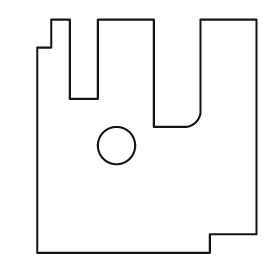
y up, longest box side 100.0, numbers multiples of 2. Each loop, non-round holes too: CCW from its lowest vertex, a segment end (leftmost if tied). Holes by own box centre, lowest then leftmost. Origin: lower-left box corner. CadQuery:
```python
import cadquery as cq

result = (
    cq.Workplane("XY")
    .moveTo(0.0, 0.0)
    .lineTo(74.0, 0.0)
    .lineTo(74.0, 8.0)
    .lineTo(94.0, 8.0)
    .lineTo(94.0, 100.0)
    .lineTo(70.0, 100.0)
    .lineTo(70.0, 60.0)
    .threePointArc((68.0, 56.0), (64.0, 54.0))
    .lineTo(50.0, 54.0)
    .lineTo(50.0, 100.0)
    .lineTo(26.0, 100.0)
    .lineTo(26.0, 66.0)
    .lineTo(14.0, 66.0)
    .lineTo(14.0, 100.0)
    .lineTo(6.0, 100.0)
    .lineTo(6.0, 88.0)
    .lineTo(0.0, 88.0)
    .close()
    .moveTo(34.0, 46.0)
    .circle(8.0)
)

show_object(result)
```